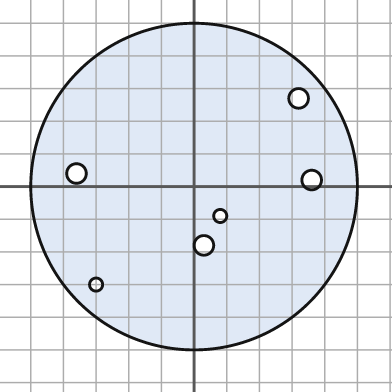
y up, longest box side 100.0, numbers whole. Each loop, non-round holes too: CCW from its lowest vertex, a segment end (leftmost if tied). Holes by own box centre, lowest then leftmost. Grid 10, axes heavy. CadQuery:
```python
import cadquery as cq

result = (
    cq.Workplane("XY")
    .moveTo(0.0, 0.0)
    .circle(50.0)
    .moveTo(-30.0, -30.0)
    .circle(2.0)
    .moveTo(3.0, -18.0)
    .circle(3.0)
    .moveTo(8.0, -9.0)
    .circle(2.0)
    .moveTo(36.0, 2.0)
    .circle(3.0)
    .moveTo(-36.0, 4.0)
    .circle(3.0)
    .moveTo(32.0, 27.0)
    .circle(3.0)
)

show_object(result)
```